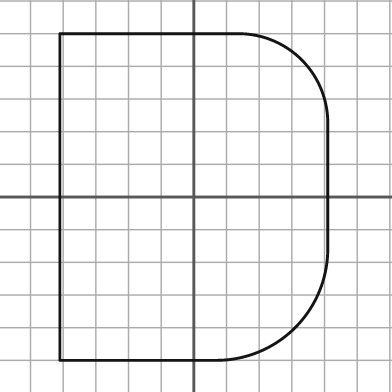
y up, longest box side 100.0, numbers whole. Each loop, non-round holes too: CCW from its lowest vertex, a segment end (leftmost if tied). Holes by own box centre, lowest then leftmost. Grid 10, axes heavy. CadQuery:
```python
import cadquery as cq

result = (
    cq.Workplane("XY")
    .moveTo(-41.0, -50.0)
    .lineTo(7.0, -50.0)
    .threePointArc((31.0, -40.0), (41.0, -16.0))
    .lineTo(41.0, 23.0)
    .threePointArc((33.0, 42.0), (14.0, 50.0))
    .lineTo(-41.0, 50.0)
    .close()
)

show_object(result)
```